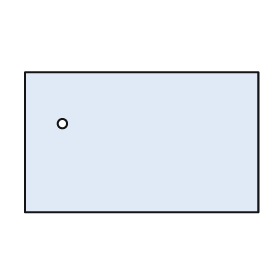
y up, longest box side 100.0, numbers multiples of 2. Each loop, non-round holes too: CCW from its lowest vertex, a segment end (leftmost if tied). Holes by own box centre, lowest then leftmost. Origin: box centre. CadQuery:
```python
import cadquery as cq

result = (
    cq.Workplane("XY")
    .moveTo(-50.0, -30.0)
    .lineTo(50.0, -30.0)
    .lineTo(50.0, 30.0)
    .lineTo(-50.0, 30.0)
    .close()
    .moveTo(-34.0, 8.0)
    .circle(2.0)
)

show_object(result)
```